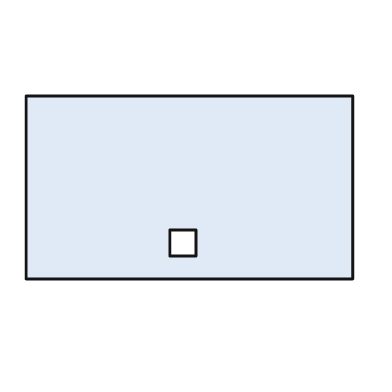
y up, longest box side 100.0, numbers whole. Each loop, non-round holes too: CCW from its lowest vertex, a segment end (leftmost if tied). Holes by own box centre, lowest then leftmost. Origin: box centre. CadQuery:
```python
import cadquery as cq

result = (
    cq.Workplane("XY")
    .moveTo(-50.0, -28.0)
    .lineTo(50.0, -28.0)
    .lineTo(50.0, 28.0)
    .lineTo(-50.0, 28.0)
    .close()
    .moveTo(-6.0, -21.0)
    .lineTo(2.0, -21.0)
    .lineTo(2.0, -13.0)
    .lineTo(-6.0, -13.0)
    .close()
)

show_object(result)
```